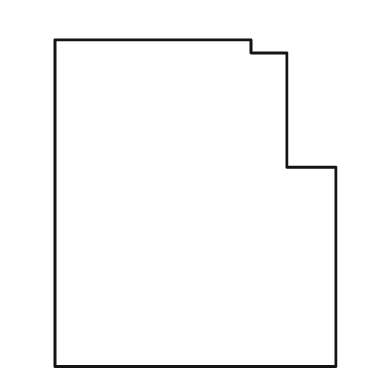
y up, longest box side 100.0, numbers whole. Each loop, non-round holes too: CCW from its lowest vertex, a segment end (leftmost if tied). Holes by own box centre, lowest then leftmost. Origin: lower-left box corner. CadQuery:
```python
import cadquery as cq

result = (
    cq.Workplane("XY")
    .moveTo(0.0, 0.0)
    .lineTo(86.0, 0.0)
    .lineTo(86.0, 61.0)
    .lineTo(71.0, 61.0)
    .lineTo(71.0, 96.0)
    .lineTo(60.0, 96.0)
    .lineTo(60.0, 100.0)
    .lineTo(0.0, 100.0)
    .close()
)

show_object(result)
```